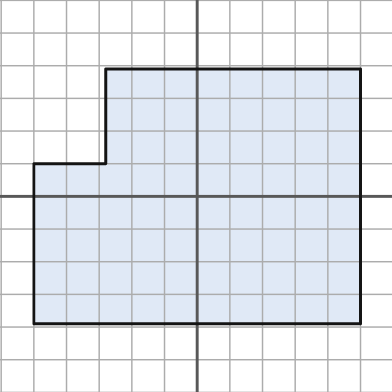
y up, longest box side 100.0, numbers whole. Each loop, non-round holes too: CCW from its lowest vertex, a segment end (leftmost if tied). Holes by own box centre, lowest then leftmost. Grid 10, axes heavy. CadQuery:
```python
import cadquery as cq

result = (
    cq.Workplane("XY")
    .moveTo(-50.0, -39.0)
    .lineTo(50.0, -39.0)
    .lineTo(50.0, 39.0)
    .lineTo(-28.0, 39.0)
    .lineTo(-28.0, 10.0)
    .lineTo(-50.0, 10.0)
    .close()
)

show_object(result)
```